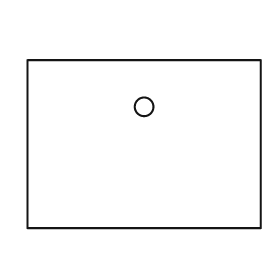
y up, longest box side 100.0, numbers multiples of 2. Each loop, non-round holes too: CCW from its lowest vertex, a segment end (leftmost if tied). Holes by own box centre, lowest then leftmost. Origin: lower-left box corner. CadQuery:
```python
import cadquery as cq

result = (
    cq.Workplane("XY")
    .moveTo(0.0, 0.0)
    .lineTo(100.0, 0.0)
    .lineTo(100.0, 72.0)
    .lineTo(0.0, 72.0)
    .close()
    .moveTo(50.0, 52.0)
    .circle(4.0)
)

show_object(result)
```